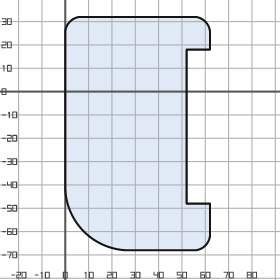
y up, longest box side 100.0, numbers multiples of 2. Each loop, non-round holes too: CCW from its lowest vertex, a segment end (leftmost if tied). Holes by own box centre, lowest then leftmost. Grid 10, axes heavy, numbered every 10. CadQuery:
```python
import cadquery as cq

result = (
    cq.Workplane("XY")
    .moveTo(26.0, -68.0)
    .lineTo(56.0, -68.0)
    .threePointArc((60.0, -66.0), (62.0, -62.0))
    .lineTo(62.0, -48.0)
    .lineTo(52.0, -48.0)
    .lineTo(52.0, 18.0)
    .lineTo(62.0, 18.0)
    .lineTo(62.0, 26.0)
    .threePointArc((60.0, 30.0), (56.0, 32.0))
    .lineTo(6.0, 32.0)
    .threePointArc((2.0, 30.0), (0.0, 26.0))
    .lineTo(0.0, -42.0)
    .threePointArc((8.0, -60.0), (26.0, -68.0))
    .close()
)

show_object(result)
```